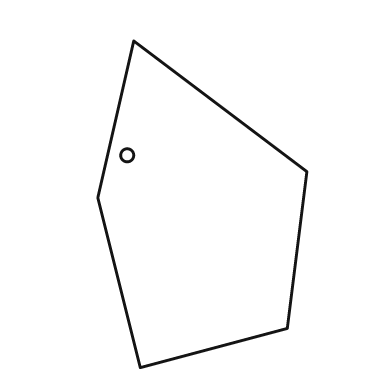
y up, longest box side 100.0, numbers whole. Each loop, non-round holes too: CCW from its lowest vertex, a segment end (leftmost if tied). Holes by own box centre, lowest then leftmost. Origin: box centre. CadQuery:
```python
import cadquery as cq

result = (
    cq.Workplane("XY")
    .moveTo(-19.0, -50.0)
    .lineTo(26.0, -38.0)
    .lineTo(32.0, 10.0)
    .lineTo(-21.0, 50.0)
    .lineTo(-32.0, 2.0)
    .close()
    .moveTo(-23.0, 15.0)
    .circle(2.0)
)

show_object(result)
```